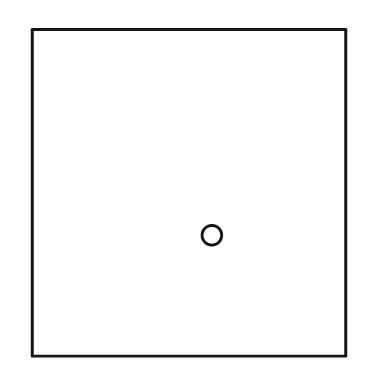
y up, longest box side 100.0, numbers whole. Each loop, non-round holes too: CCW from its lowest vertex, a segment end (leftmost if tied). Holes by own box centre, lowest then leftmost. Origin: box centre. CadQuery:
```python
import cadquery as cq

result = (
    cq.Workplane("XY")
    .moveTo(-48.0, -50.0)
    .lineTo(48.0, -50.0)
    .lineTo(48.0, 50.0)
    .lineTo(-48.0, 50.0)
    .close()
    .moveTo(7.0, -13.0)
    .circle(3.0)
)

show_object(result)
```